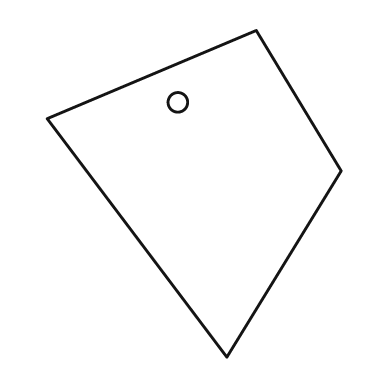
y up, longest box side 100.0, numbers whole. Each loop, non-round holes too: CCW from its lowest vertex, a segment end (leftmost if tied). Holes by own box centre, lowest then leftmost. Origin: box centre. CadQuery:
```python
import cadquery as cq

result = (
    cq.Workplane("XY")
    .moveTo(10.0, -50.0)
    .lineTo(45.0, 7.0)
    .lineTo(19.0, 50.0)
    .lineTo(-45.0, 23.0)
    .close()
    .moveTo(-5.0, 28.0)
    .circle(3.0)
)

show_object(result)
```